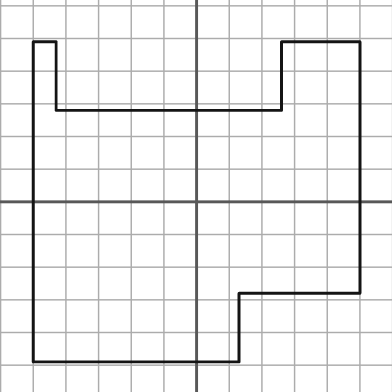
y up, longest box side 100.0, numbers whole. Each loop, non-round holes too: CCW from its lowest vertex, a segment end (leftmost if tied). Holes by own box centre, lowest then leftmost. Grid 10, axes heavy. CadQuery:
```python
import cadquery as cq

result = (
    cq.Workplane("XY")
    .moveTo(-50.0, -49.0)
    .lineTo(13.0, -49.0)
    .lineTo(13.0, -28.0)
    .lineTo(50.0, -28.0)
    .lineTo(50.0, 49.0)
    .lineTo(26.0, 49.0)
    .lineTo(26.0, 28.0)
    .lineTo(-43.0, 28.0)
    .lineTo(-43.0, 49.0)
    .lineTo(-50.0, 49.0)
    .close()
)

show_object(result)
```